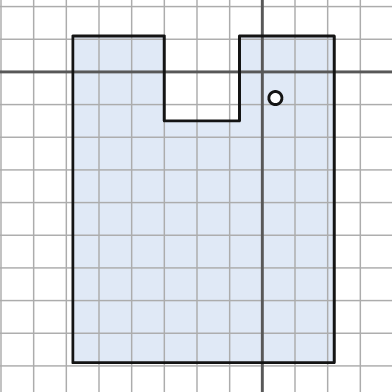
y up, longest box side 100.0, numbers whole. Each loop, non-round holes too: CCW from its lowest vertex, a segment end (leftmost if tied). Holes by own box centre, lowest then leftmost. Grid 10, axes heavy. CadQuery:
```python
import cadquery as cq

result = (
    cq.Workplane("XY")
    .moveTo(-58.0, -89.0)
    .lineTo(22.0, -89.0)
    .lineTo(22.0, 11.0)
    .lineTo(-7.0, 11.0)
    .lineTo(-7.0, -15.0)
    .lineTo(-30.0, -15.0)
    .lineTo(-30.0, 11.0)
    .lineTo(-58.0, 11.0)
    .close()
    .moveTo(4.0, -8.0)
    .circle(2.0)
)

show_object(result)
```